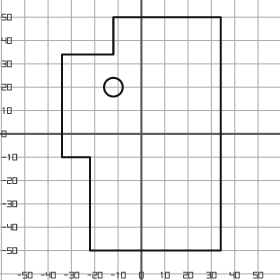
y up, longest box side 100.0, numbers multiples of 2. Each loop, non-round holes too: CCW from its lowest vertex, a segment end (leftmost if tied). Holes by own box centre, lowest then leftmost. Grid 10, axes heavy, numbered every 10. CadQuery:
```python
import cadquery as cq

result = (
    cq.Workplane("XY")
    .moveTo(-22.0, -50.0)
    .lineTo(34.0, -50.0)
    .lineTo(34.0, 50.0)
    .lineTo(-12.0, 50.0)
    .lineTo(-12.0, 34.0)
    .lineTo(-34.0, 34.0)
    .lineTo(-34.0, -10.0)
    .lineTo(-22.0, -10.0)
    .close()
    .moveTo(-12.0, 20.0)
    .circle(4.0)
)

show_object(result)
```